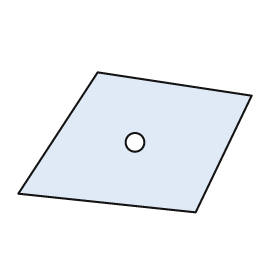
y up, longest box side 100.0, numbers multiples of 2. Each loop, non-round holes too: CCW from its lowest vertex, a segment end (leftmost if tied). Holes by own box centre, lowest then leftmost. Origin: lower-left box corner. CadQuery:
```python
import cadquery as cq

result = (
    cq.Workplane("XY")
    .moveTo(76.0, 0.0)
    .lineTo(100.0, 50.0)
    .lineTo(34.0, 60.0)
    .lineTo(0.0, 8.0)
    .close()
    .moveTo(50.0, 30.0)
    .circle(4.0)
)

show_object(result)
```